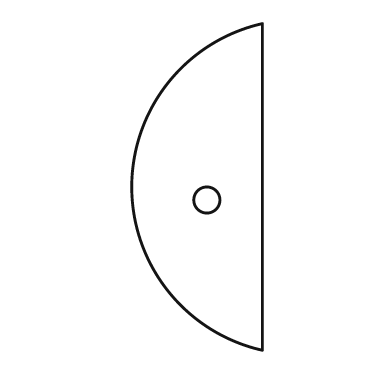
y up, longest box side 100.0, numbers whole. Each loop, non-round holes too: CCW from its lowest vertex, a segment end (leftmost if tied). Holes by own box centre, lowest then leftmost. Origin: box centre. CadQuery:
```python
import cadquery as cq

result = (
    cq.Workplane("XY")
    .moveTo(20.0, -50.0)
    .lineTo(20.0, 50.0)
    .threePointArc((-20.0, 0.0), (20.0, -50.0))
    .close()
    .moveTo(3.0, -4.0)
    .circle(4.0)
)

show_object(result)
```